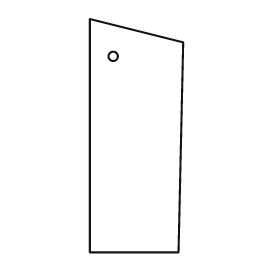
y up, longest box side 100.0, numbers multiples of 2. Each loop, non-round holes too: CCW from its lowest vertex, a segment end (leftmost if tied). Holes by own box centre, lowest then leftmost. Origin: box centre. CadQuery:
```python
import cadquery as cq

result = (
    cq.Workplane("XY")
    .moveTo(-20.0, -50.0)
    .lineTo(18.0, -50.0)
    .lineTo(20.0, 40.0)
    .lineTo(-20.0, 50.0)
    .close()
    .moveTo(-10.0, 34.0)
    .circle(2.0)
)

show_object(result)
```